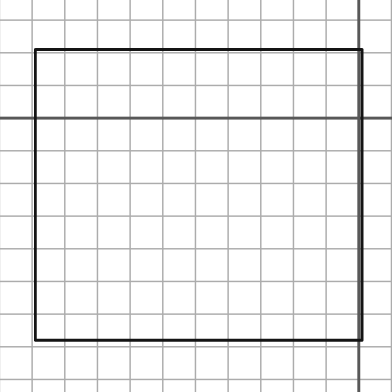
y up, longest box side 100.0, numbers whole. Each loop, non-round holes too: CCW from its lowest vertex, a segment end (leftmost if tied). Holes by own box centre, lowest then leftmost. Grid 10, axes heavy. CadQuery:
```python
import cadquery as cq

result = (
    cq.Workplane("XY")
    .moveTo(-99.0, -68.0)
    .lineTo(1.0, -68.0)
    .lineTo(1.0, 21.0)
    .lineTo(-99.0, 21.0)
    .close()
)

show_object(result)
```